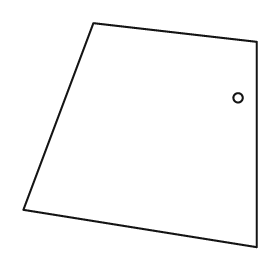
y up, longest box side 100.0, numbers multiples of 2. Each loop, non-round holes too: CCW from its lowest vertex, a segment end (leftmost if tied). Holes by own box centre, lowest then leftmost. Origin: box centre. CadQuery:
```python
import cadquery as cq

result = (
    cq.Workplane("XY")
    .moveTo(50.0, -48.0)
    .lineTo(50.0, 40.0)
    .lineTo(-20.0, 48.0)
    .lineTo(-50.0, -32.0)
    .close()
    .moveTo(42.0, 16.0)
    .circle(2.0)
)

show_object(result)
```